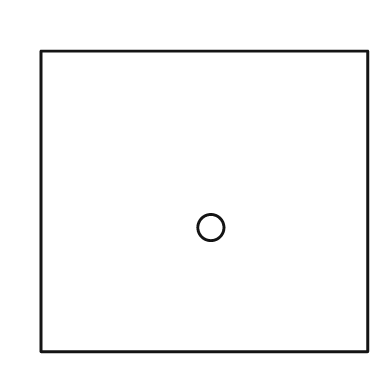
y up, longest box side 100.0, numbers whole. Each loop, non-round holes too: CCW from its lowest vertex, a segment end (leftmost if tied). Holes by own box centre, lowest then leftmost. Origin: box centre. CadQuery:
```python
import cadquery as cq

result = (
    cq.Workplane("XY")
    .moveTo(-50.0, -46.0)
    .lineTo(50.0, -46.0)
    .lineTo(50.0, 46.0)
    .lineTo(-50.0, 46.0)
    .close()
    .moveTo(2.0, -8.0)
    .circle(4.0)
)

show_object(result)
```